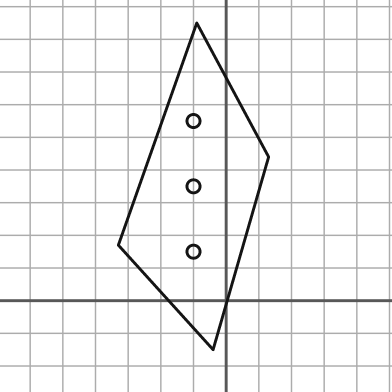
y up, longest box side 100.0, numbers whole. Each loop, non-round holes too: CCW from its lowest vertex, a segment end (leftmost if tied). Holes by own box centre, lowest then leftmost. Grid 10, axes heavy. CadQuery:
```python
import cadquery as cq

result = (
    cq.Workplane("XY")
    .moveTo(-4.0, -15.0)
    .lineTo(13.0, 44.0)
    .lineTo(-9.0, 85.0)
    .lineTo(-33.0, 17.0)
    .close()
    .moveTo(-10.0, 15.0)
    .circle(2.0)
    .moveTo(-10.0, 35.0)
    .circle(2.0)
    .moveTo(-10.0, 55.0)
    .circle(2.0)
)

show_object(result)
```